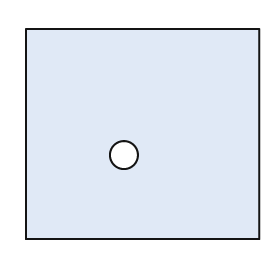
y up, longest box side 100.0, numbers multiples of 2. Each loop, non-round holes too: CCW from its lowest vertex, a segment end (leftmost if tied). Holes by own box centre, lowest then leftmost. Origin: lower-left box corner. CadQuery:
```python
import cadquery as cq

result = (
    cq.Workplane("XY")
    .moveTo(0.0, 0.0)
    .lineTo(100.0, 0.0)
    .lineTo(100.0, 90.0)
    .lineTo(0.0, 90.0)
    .close()
    .moveTo(42.0, 36.0)
    .circle(6.0)
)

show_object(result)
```